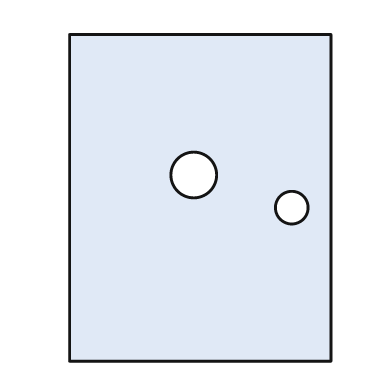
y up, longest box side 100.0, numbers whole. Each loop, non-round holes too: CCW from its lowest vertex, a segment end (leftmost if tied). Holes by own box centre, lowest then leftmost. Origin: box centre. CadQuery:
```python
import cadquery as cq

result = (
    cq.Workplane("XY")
    .moveTo(-40.0, -50.0)
    .lineTo(40.0, -50.0)
    .lineTo(40.0, 50.0)
    .lineTo(-40.0, 50.0)
    .close()
    .moveTo(28.0, -3.0)
    .circle(5.0)
    .moveTo(-2.0, 7.0)
    .circle(7.0)
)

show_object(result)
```